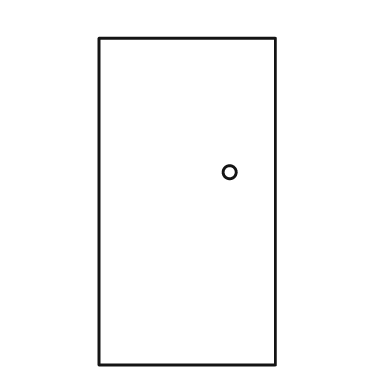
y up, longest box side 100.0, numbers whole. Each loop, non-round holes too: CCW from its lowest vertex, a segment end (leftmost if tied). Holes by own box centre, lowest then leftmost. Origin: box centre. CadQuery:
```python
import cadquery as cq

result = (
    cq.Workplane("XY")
    .moveTo(-27.0, -50.0)
    .lineTo(27.0, -50.0)
    .lineTo(27.0, 50.0)
    .lineTo(-27.0, 50.0)
    .close()
    .moveTo(13.0, 9.0)
    .circle(2.0)
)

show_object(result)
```